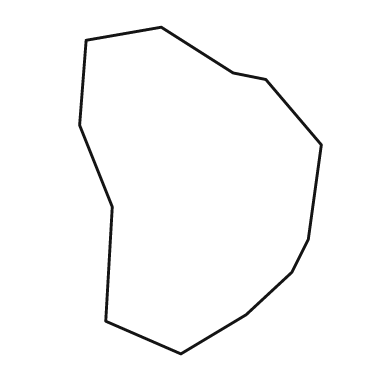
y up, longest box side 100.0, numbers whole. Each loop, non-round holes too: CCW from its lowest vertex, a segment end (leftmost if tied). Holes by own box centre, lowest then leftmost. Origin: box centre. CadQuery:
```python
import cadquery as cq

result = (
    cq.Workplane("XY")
    .moveTo(-6.0, -50.0)
    .lineTo(14.0, -38.0)
    .lineTo(28.0, -25.0)
    .lineTo(33.0, -15.0)
    .lineTo(37.0, 14.0)
    .lineTo(20.0, 34.0)
    .lineTo(10.0, 36.0)
    .lineTo(-12.0, 50.0)
    .lineTo(-35.0, 46.0)
    .lineTo(-37.0, 20.0)
    .lineTo(-27.0, -5.0)
    .lineTo(-29.0, -40.0)
    .close()
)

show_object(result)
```